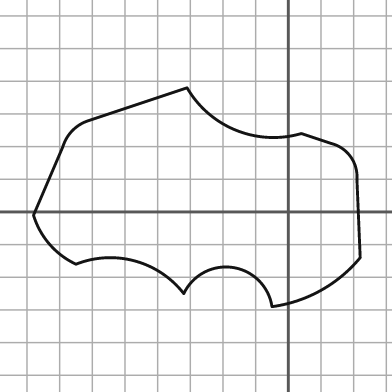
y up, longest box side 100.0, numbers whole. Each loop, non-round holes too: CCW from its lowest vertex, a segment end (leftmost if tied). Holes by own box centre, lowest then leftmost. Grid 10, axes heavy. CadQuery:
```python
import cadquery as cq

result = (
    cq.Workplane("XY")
    .moveTo(-5.0, -29.0)
    .threePointArc((10.0, -24.0), (22.0, -14.0))
    .lineTo(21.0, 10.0)
    .threePointArc((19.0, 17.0), (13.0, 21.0))
    .lineTo(4.0, 24.0)
    .threePointArc((-16.0, 25.0), (-31.0, 38.0))
    .lineTo(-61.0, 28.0)
    .threePointArc((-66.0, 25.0), (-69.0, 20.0))
    .lineTo(-78.0, -1.0)
    .threePointArc((-73.0, -10.0), (-65.0, -16.0))
    .threePointArc((-47.0, -15.0), (-32.0, -25.0))
    .threePointArc((-17.0, -17.0), (-5.0, -29.0))
    .close()
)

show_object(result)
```